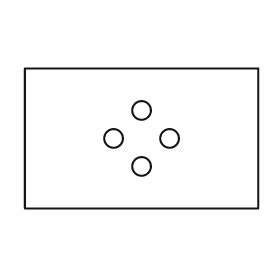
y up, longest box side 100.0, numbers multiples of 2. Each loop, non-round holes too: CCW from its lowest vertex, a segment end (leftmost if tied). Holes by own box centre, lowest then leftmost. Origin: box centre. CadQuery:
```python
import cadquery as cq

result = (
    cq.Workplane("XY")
    .moveTo(-50.0, -30.0)
    .lineTo(50.0, -30.0)
    .lineTo(50.0, 30.0)
    .lineTo(-50.0, 30.0)
    .close()
    .moveTo(0.0, -12.0)
    .circle(4.0)
    .moveTo(-12.0, 0.0)
    .circle(4.0)
    .moveTo(12.0, 0.0)
    .circle(4.0)
    .moveTo(0.0, 12.0)
    .circle(4.0)
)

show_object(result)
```